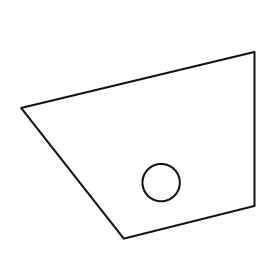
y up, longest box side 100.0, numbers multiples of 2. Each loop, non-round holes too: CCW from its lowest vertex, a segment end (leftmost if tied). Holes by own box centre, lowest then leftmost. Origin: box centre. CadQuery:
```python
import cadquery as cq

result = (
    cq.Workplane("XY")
    .moveTo(-6.0, -40.0)
    .lineTo(50.0, -26.0)
    .lineTo(50.0, 40.0)
    .lineTo(-50.0, 16.0)
    .close()
    .moveTo(10.0, -16.0)
    .circle(8.0)
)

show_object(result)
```